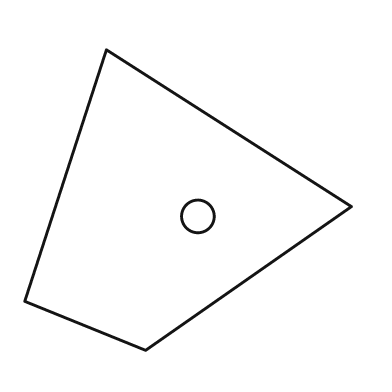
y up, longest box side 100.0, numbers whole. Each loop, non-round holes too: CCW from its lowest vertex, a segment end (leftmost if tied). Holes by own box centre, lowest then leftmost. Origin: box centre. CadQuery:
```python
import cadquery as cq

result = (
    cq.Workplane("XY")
    .moveTo(-13.0, -46.0)
    .lineTo(50.0, -2.0)
    .lineTo(-25.0, 46.0)
    .lineTo(-50.0, -31.0)
    .close()
    .moveTo(3.0, -5.0)
    .circle(5.0)
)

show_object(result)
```